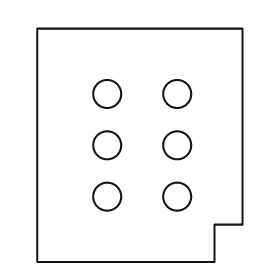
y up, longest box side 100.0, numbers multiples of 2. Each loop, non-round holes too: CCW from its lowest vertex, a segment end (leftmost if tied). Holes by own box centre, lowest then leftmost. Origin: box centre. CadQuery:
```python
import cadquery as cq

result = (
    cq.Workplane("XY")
    .moveTo(-44.0, -50.0)
    .lineTo(32.0, -50.0)
    .lineTo(32.0, -34.0)
    .lineTo(44.0, -34.0)
    .lineTo(44.0, 50.0)
    .lineTo(-44.0, 50.0)
    .close()
    .moveTo(-14.0, -22.0)
    .circle(6.0)
    .moveTo(16.0, -22.0)
    .circle(6.0)
    .moveTo(-14.0, 0.0)
    .circle(6.0)
    .moveTo(16.0, 0.0)
    .circle(6.0)
    .moveTo(-14.0, 22.0)
    .circle(6.0)
    .moveTo(16.0, 22.0)
    .circle(6.0)
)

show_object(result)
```